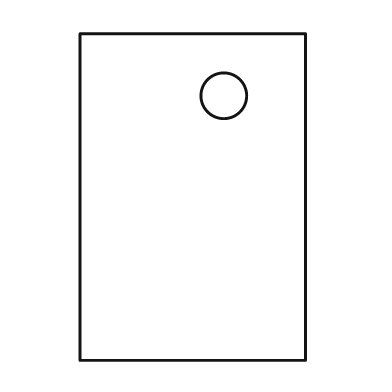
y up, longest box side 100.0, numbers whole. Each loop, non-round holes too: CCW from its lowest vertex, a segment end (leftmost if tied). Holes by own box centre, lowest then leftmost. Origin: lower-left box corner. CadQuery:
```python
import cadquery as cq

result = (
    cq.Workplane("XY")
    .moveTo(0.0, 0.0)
    .lineTo(69.0, 0.0)
    .lineTo(69.0, 100.0)
    .lineTo(0.0, 100.0)
    .close()
    .moveTo(44.0, 81.0)
    .circle(7.0)
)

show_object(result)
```